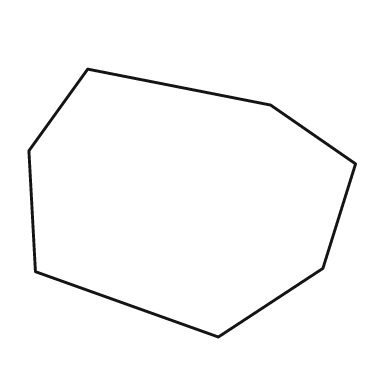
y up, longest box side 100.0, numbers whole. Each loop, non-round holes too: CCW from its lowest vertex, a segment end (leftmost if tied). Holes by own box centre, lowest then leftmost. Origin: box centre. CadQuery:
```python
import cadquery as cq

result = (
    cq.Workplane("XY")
    .moveTo(8.0, -41.0)
    .lineTo(40.0, -20.0)
    .lineTo(50.0, 12.0)
    .lineTo(24.0, 30.0)
    .lineTo(-32.0, 41.0)
    .lineTo(-50.0, 16.0)
    .lineTo(-48.0, -21.0)
    .close()
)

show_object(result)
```